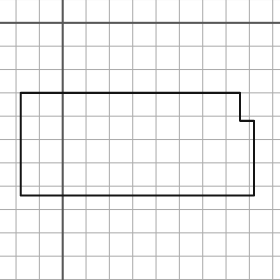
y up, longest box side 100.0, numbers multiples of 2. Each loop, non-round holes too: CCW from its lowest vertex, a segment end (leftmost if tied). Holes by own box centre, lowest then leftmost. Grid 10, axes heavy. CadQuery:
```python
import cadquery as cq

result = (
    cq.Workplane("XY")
    .moveTo(-18.0, -74.0)
    .lineTo(82.0, -74.0)
    .lineTo(82.0, -42.0)
    .lineTo(76.0, -42.0)
    .lineTo(76.0, -30.0)
    .lineTo(-18.0, -30.0)
    .close()
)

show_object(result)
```